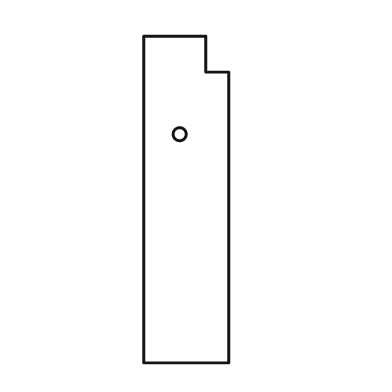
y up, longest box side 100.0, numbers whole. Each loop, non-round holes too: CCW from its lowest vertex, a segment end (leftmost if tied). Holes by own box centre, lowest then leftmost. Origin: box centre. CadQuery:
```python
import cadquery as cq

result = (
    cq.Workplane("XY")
    .moveTo(-13.0, -50.0)
    .lineTo(13.0, -50.0)
    .lineTo(13.0, 39.0)
    .lineTo(6.0, 39.0)
    .lineTo(6.0, 50.0)
    .lineTo(-13.0, 50.0)
    .close()
    .moveTo(-2.0, 20.0)
    .circle(2.0)
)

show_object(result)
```